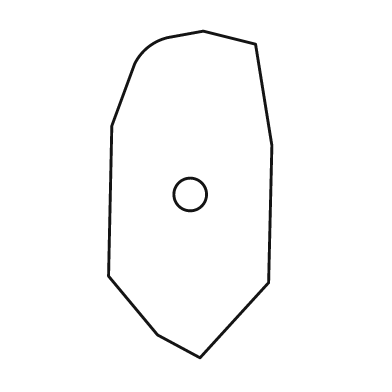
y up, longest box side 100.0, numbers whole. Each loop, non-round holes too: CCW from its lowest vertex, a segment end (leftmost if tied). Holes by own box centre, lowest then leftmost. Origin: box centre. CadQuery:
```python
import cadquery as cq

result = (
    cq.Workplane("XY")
    .moveTo(3.0, -50.0)
    .lineTo(24.0, -27.0)
    .lineTo(25.0, 15.0)
    .lineTo(20.0, 46.0)
    .lineTo(4.0, 50.0)
    .lineTo(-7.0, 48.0)
    .threePointArc((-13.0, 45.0), (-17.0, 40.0))
    .lineTo(-24.0, 21.0)
    .lineTo(-25.0, -25.0)
    .lineTo(-10.0, -43.0)
    .close()
    .moveTo(0.0, 0.0)
    .circle(5.0)
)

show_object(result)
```